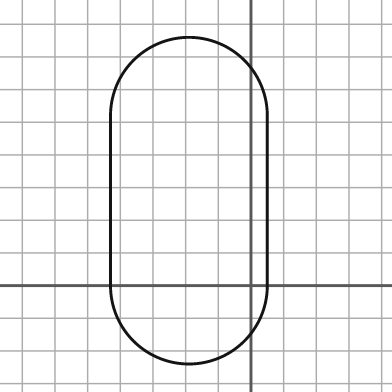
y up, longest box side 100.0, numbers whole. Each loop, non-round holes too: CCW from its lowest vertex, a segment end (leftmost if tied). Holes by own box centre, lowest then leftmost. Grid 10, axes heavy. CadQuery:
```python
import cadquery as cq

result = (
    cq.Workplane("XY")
    .moveTo(-43.0, 0.0)
    .threePointArc((-19.0, -24.0), (5.0, 0.0))
    .lineTo(5.0, 52.0)
    .threePointArc((-19.0, 76.0), (-43.0, 52.0))
    .close()
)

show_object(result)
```